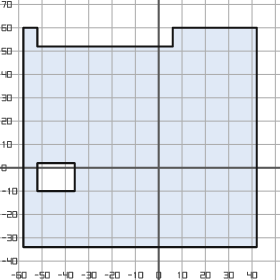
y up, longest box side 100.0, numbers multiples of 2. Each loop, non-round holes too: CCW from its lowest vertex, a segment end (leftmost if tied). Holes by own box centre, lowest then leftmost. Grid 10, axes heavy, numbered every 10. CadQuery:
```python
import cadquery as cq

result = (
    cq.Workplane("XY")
    .moveTo(-58.0, -34.0)
    .lineTo(42.0, -34.0)
    .lineTo(42.0, 60.0)
    .lineTo(6.0, 60.0)
    .lineTo(6.0, 52.0)
    .lineTo(-52.0, 52.0)
    .lineTo(-52.0, 60.0)
    .lineTo(-58.0, 60.0)
    .close()
    .moveTo(-52.0, -10.0)
    .lineTo(-36.0, -10.0)
    .lineTo(-36.0, 2.0)
    .lineTo(-52.0, 2.0)
    .close()
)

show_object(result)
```